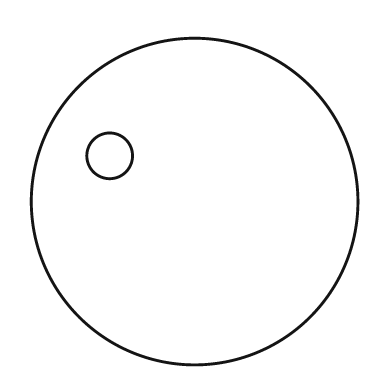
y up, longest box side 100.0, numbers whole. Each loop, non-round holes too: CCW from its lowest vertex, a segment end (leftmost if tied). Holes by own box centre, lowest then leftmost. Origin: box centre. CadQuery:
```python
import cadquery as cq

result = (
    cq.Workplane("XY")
    .moveTo(0.0, 0.0)
    .circle(50.0)
    .moveTo(-26.0, 14.0)
    .circle(7.0)
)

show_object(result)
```